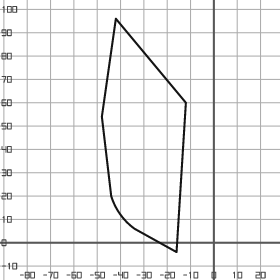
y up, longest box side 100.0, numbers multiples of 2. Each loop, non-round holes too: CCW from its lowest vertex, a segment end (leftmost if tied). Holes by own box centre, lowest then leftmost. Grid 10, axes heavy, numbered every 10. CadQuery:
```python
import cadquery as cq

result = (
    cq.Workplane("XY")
    .moveTo(-16.0, -4.0)
    .lineTo(-12.0, 60.0)
    .lineTo(-42.0, 96.0)
    .lineTo(-48.0, 54.0)
    .lineTo(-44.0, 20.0)
    .threePointArc((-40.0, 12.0), (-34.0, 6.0))
    .close()
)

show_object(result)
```